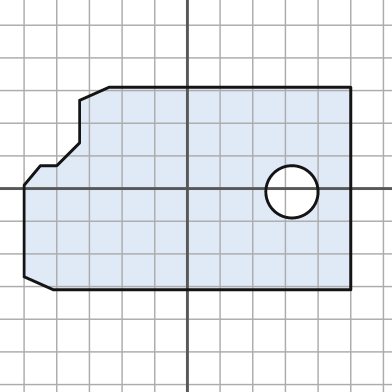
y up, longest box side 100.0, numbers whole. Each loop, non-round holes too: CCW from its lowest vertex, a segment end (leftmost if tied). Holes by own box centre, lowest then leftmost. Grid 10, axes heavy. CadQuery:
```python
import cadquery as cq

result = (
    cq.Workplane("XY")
    .moveTo(-41.0, -31.0)
    .lineTo(50.0, -31.0)
    .lineTo(50.0, 31.0)
    .lineTo(-24.0, 31.0)
    .lineTo(-33.0, 27.0)
    .lineTo(-33.0, 14.0)
    .lineTo(-40.0, 7.0)
    .lineTo(-45.0, 7.0)
    .lineTo(-50.0, 1.0)
    .lineTo(-50.0, -27.0)
    .close()
    .moveTo(32.0, -1.0)
    .circle(8.0)
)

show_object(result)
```